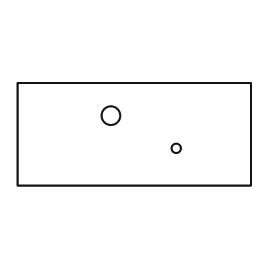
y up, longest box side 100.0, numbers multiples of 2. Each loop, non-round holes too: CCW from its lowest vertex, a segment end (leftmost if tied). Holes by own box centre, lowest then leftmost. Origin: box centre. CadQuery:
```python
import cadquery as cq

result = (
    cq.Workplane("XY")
    .moveTo(-50.0, -22.0)
    .lineTo(50.0, -22.0)
    .lineTo(50.0, 22.0)
    .lineTo(-50.0, 22.0)
    .close()
    .moveTo(18.0, -6.0)
    .circle(2.0)
    .moveTo(-10.0, 8.0)
    .circle(4.0)
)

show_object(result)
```